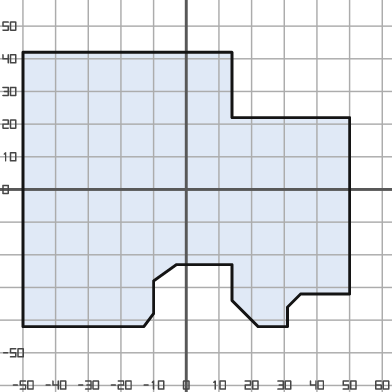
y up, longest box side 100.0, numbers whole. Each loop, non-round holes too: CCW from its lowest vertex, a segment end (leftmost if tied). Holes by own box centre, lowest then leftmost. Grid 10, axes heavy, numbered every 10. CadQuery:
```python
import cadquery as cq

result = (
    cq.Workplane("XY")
    .moveTo(-50.0, -42.0)
    .lineTo(-13.0, -42.0)
    .lineTo(-10.0, -38.0)
    .lineTo(-10.0, -28.0)
    .lineTo(-3.0, -23.0)
    .lineTo(14.0, -23.0)
    .lineTo(14.0, -34.0)
    .lineTo(22.0, -42.0)
    .lineTo(31.0, -42.0)
    .lineTo(31.0, -36.0)
    .lineTo(35.0, -32.0)
    .lineTo(50.0, -32.0)
    .lineTo(50.0, 22.0)
    .lineTo(14.0, 22.0)
    .lineTo(14.0, 42.0)
    .lineTo(-50.0, 42.0)
    .close()
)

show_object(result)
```